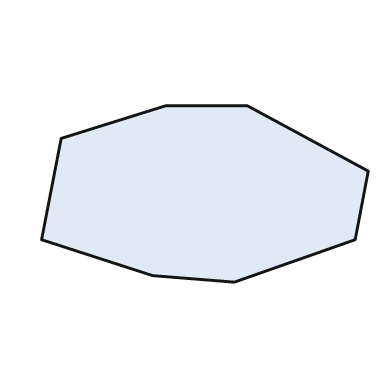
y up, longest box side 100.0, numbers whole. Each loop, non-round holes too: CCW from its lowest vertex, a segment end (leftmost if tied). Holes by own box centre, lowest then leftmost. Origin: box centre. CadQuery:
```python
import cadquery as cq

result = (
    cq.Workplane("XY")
    .moveTo(9.0, -27.0)
    .lineTo(46.0, -14.0)
    .lineTo(50.0, 7.0)
    .lineTo(13.0, 27.0)
    .lineTo(-12.0, 27.0)
    .lineTo(-44.0, 17.0)
    .lineTo(-50.0, -14.0)
    .lineTo(-16.0, -25.0)
    .close()
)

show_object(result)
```